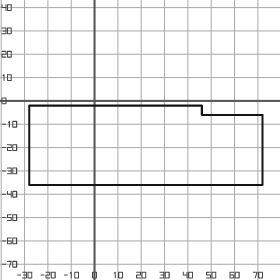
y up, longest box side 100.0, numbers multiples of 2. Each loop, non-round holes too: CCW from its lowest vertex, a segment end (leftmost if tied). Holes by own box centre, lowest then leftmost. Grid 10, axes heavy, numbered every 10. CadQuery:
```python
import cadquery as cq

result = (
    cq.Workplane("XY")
    .moveTo(-28.0, -36.0)
    .lineTo(72.0, -36.0)
    .lineTo(72.0, -6.0)
    .lineTo(46.0, -6.0)
    .lineTo(46.0, -2.0)
    .lineTo(-28.0, -2.0)
    .close()
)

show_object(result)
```